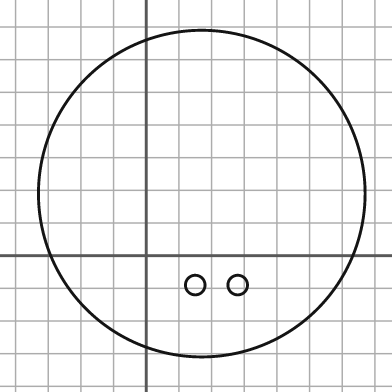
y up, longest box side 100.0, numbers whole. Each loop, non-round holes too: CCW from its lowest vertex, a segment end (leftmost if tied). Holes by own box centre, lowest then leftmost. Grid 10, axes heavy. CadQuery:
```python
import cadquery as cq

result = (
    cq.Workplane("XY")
    .moveTo(17.0, 19.0)
    .circle(50.0)
    .moveTo(15.0, -9.0)
    .circle(3.0)
    .moveTo(28.0, -9.0)
    .circle(3.0)
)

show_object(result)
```